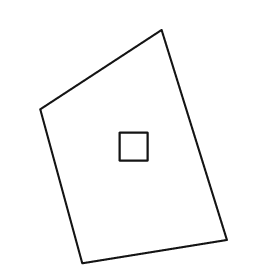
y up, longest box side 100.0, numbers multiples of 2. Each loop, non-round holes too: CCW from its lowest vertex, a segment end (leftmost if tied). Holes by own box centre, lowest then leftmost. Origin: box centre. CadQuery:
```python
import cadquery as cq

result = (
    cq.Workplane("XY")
    .moveTo(-22.0, -50.0)
    .lineTo(40.0, -40.0)
    .lineTo(12.0, 50.0)
    .lineTo(-40.0, 16.0)
    .close()
    .moveTo(-6.0, -6.0)
    .lineTo(6.0, -6.0)
    .lineTo(6.0, 6.0)
    .lineTo(-6.0, 6.0)
    .close()
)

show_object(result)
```